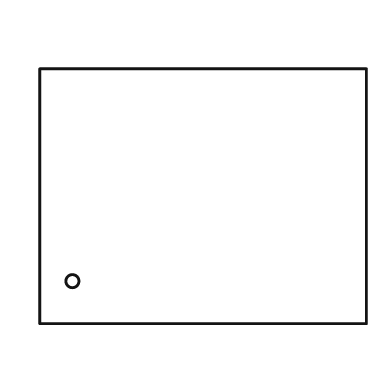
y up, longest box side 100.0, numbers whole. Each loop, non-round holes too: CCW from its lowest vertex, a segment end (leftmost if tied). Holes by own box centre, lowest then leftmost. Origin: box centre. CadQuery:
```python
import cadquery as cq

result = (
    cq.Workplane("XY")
    .moveTo(-50.0, -39.0)
    .lineTo(50.0, -39.0)
    .lineTo(50.0, 39.0)
    .lineTo(-50.0, 39.0)
    .close()
    .moveTo(-40.0, -26.0)
    .circle(2.0)
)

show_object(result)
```